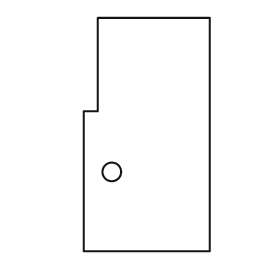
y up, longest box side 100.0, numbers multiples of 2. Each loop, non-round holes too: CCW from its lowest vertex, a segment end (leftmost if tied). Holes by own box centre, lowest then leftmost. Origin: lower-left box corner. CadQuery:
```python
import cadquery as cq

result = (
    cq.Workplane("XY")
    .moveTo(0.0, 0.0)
    .lineTo(54.0, 0.0)
    .lineTo(54.0, 100.0)
    .lineTo(6.0, 100.0)
    .lineTo(6.0, 60.0)
    .lineTo(0.0, 60.0)
    .close()
    .moveTo(12.0, 34.0)
    .circle(4.0)
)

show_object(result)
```